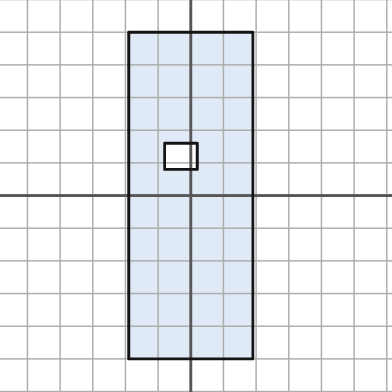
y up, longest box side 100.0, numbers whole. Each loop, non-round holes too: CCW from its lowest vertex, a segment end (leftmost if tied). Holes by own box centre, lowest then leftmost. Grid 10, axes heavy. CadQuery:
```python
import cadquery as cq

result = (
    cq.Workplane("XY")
    .moveTo(-19.0, -50.0)
    .lineTo(19.0, -50.0)
    .lineTo(19.0, 50.0)
    .lineTo(-19.0, 50.0)
    .close()
    .moveTo(-8.0, 8.0)
    .lineTo(2.0, 8.0)
    .lineTo(2.0, 16.0)
    .lineTo(-8.0, 16.0)
    .close()
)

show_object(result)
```